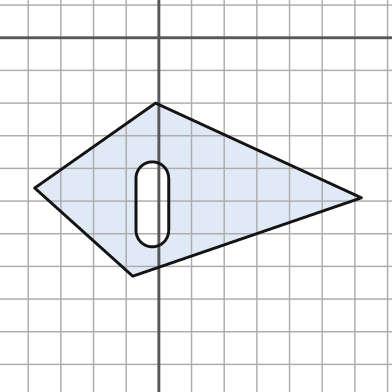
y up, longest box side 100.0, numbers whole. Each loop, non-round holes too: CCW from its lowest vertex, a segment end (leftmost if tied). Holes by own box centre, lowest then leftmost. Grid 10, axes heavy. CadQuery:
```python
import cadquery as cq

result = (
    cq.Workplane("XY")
    .moveTo(-8.0, -73.0)
    .lineTo(62.0, -49.0)
    .lineTo(-1.0, -20.0)
    .lineTo(-38.0, -46.0)
    .close()
    .moveTo(-7.0, -59.0)
    .threePointArc((-2.0, -64.0), (3.0, -59.0))
    .lineTo(3.0, -43.0)
    .threePointArc((-2.0, -38.0), (-7.0, -43.0))
    .close()
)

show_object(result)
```